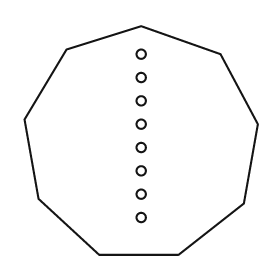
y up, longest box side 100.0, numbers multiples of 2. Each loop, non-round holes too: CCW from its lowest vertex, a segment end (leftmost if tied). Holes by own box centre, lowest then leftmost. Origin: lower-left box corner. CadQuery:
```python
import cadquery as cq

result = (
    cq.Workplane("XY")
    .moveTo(32.0, 0.0)
    .lineTo(66.0, 0.0)
    .lineTo(94.0, 22.0)
    .lineTo(100.0, 56.0)
    .lineTo(84.0, 86.0)
    .lineTo(50.0, 98.0)
    .lineTo(18.0, 88.0)
    .lineTo(0.0, 58.0)
    .lineTo(6.0, 24.0)
    .close()
    .moveTo(50.0, 16.0)
    .circle(2.0)
    .moveTo(50.0, 26.0)
    .circle(2.0)
    .moveTo(50.0, 36.0)
    .circle(2.0)
    .moveTo(50.0, 46.0)
    .circle(2.0)
    .moveTo(50.0, 56.0)
    .circle(2.0)
    .moveTo(50.0, 66.0)
    .circle(2.0)
    .moveTo(50.0, 76.0)
    .circle(2.0)
    .moveTo(50.0, 86.0)
    .circle(2.0)
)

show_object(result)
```